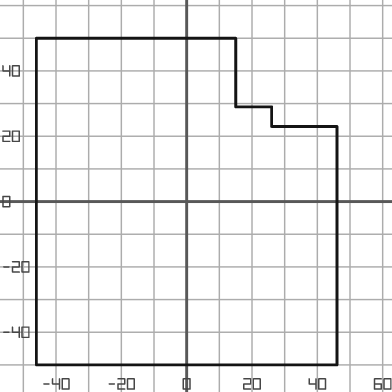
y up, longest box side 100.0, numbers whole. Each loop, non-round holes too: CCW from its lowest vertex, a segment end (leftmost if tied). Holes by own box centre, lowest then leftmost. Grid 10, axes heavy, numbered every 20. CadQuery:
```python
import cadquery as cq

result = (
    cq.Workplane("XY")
    .moveTo(-46.0, -50.0)
    .lineTo(46.0, -50.0)
    .lineTo(46.0, 23.0)
    .lineTo(26.0, 23.0)
    .lineTo(26.0, 29.0)
    .lineTo(15.0, 29.0)
    .lineTo(15.0, 50.0)
    .lineTo(-46.0, 50.0)
    .close()
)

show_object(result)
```